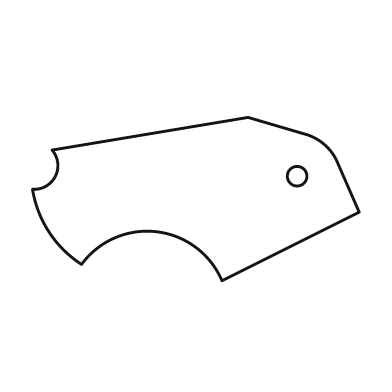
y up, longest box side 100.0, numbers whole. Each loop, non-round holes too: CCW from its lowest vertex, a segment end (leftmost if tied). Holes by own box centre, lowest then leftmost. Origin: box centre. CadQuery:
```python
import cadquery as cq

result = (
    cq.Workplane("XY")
    .moveTo(8.0, -25.0)
    .lineTo(50.0, -4.0)
    .lineTo(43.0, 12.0)
    .threePointArc((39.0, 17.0), (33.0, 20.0))
    .lineTo(16.0, 25.0)
    .lineTo(-44.0, 15.0)
    .threePointArc((-43.0, 7.0), (-50.0, 3.0))
    .threePointArc((-45.0, -10.0), (-35.0, -20.0))
    .threePointArc((-12.0, -10.0), (8.0, -25.0))
    .close()
    .moveTo(31.0, 7.0)
    .circle(3.0)
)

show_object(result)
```